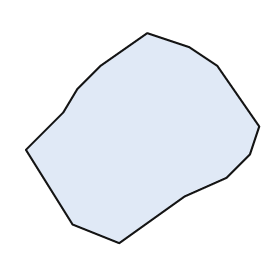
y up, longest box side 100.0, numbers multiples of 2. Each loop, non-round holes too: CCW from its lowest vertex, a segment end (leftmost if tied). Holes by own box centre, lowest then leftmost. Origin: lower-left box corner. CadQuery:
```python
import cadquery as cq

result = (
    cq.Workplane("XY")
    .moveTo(40.0, 0.0)
    .lineTo(68.0, 20.0)
    .lineTo(86.0, 28.0)
    .lineTo(96.0, 38.0)
    .lineTo(100.0, 50.0)
    .lineTo(82.0, 76.0)
    .lineTo(70.0, 84.0)
    .lineTo(52.0, 90.0)
    .lineTo(32.0, 76.0)
    .lineTo(22.0, 66.0)
    .lineTo(16.0, 56.0)
    .lineTo(0.0, 40.0)
    .lineTo(20.0, 8.0)
    .close()
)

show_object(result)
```